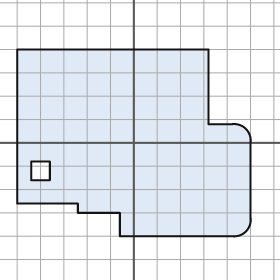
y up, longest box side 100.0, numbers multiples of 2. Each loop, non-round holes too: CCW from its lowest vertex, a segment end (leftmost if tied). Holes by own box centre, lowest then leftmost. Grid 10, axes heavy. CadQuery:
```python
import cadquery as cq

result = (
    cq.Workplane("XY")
    .moveTo(-6.0, -40.0)
    .lineTo(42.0, -40.0)
    .threePointArc((48.0, -38.0), (50.0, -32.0))
    .lineTo(50.0, 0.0)
    .threePointArc((48.0, 6.0), (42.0, 8.0))
    .lineTo(32.0, 8.0)
    .lineTo(32.0, 40.0)
    .lineTo(-50.0, 40.0)
    .lineTo(-50.0, -26.0)
    .lineTo(-24.0, -26.0)
    .lineTo(-24.0, -30.0)
    .lineTo(-6.0, -30.0)
    .close()
    .moveTo(-44.0, -16.0)
    .lineTo(-36.0, -16.0)
    .lineTo(-36.0, -8.0)
    .lineTo(-44.0, -8.0)
    .close()
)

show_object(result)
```